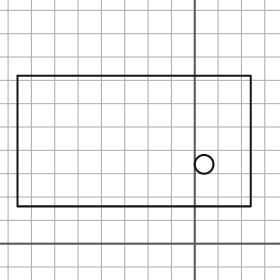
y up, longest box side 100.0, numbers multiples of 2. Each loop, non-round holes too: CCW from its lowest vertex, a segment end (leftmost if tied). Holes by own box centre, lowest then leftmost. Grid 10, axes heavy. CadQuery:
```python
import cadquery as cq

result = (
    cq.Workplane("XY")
    .moveTo(-76.0, 16.0)
    .lineTo(24.0, 16.0)
    .lineTo(24.0, 72.0)
    .lineTo(-76.0, 72.0)
    .close()
    .moveTo(4.0, 34.0)
    .circle(4.0)
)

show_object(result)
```